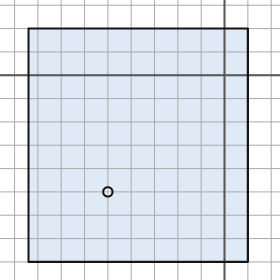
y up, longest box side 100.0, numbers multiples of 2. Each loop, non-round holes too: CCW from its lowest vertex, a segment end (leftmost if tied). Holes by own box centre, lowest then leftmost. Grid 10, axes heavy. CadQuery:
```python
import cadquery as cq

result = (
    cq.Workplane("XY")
    .moveTo(-84.0, -80.0)
    .lineTo(10.0, -80.0)
    .lineTo(10.0, 20.0)
    .lineTo(-84.0, 20.0)
    .close()
    .moveTo(-50.0, -50.0)
    .circle(2.0)
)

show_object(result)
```